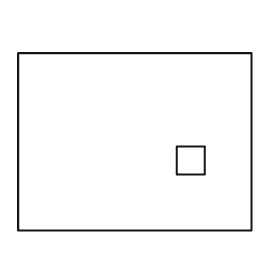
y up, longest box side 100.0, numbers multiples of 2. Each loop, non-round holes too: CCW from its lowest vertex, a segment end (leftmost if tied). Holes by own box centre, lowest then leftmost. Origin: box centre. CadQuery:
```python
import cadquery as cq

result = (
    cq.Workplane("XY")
    .moveTo(-50.0, -38.0)
    .lineTo(50.0, -38.0)
    .lineTo(50.0, 38.0)
    .lineTo(-50.0, 38.0)
    .close()
    .moveTo(18.0, -14.0)
    .lineTo(30.0, -14.0)
    .lineTo(30.0, -2.0)
    .lineTo(18.0, -2.0)
    .close()
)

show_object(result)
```